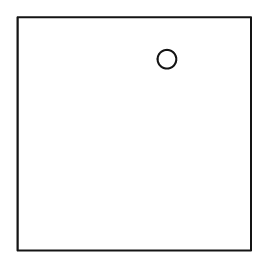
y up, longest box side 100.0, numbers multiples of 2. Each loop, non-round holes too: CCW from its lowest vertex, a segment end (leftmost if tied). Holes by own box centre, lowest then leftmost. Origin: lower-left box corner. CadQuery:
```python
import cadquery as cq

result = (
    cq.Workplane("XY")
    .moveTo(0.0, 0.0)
    .lineTo(100.0, 0.0)
    .lineTo(100.0, 100.0)
    .lineTo(0.0, 100.0)
    .close()
    .moveTo(64.0, 82.0)
    .circle(4.0)
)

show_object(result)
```